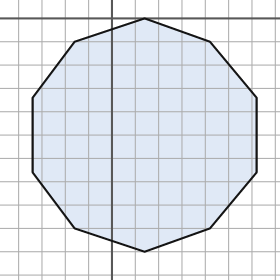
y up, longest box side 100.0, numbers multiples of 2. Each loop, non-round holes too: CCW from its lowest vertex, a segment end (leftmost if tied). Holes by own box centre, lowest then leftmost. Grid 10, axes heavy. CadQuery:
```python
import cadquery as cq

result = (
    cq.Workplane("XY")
    .moveTo(14.0, -100.0)
    .lineTo(42.0, -90.0)
    .lineTo(62.0, -66.0)
    .lineTo(62.0, -34.0)
    .lineTo(42.0, -10.0)
    .lineTo(14.0, 0.0)
    .lineTo(-16.0, -10.0)
    .lineTo(-34.0, -34.0)
    .lineTo(-34.0, -66.0)
    .lineTo(-16.0, -90.0)
    .close()
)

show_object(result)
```